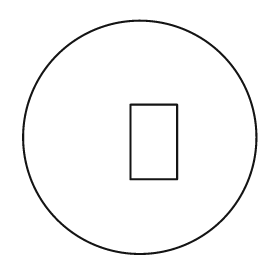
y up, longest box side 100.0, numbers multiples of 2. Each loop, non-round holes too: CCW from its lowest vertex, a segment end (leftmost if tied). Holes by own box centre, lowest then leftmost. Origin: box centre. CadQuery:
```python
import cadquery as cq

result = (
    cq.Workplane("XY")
    .moveTo(0.0, 0.0)
    .circle(50.0)
    .moveTo(-4.0, -18.0)
    .lineTo(16.0, -18.0)
    .lineTo(16.0, 14.0)
    .lineTo(-4.0, 14.0)
    .close()
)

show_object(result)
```